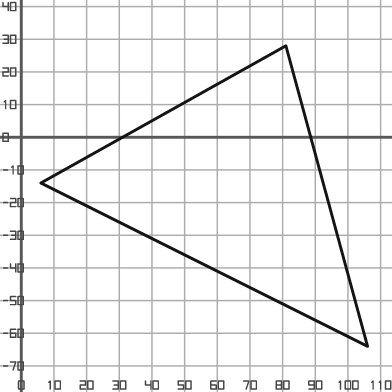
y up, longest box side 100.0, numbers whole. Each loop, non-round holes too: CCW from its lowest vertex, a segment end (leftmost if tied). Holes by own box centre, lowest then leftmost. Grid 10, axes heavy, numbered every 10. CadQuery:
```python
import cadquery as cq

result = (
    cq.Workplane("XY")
    .moveTo(106.0, -64.0)
    .lineTo(81.0, 28.0)
    .lineTo(6.0, -14.0)
    .close()
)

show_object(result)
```